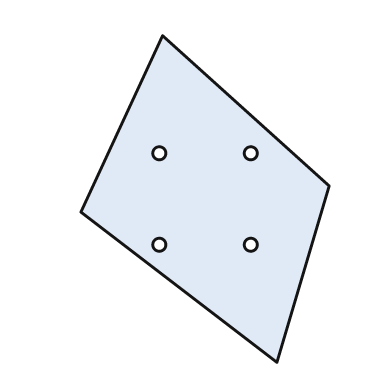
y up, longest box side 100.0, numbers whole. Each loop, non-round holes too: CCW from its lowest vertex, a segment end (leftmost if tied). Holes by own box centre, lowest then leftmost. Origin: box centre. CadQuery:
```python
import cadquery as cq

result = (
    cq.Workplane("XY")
    .moveTo(22.0, -50.0)
    .lineTo(38.0, 4.0)
    .lineTo(-13.0, 50.0)
    .lineTo(-38.0, -4.0)
    .close()
    .moveTo(-14.0, -14.0)
    .circle(2.0)
    .moveTo(14.0, -14.0)
    .circle(2.0)
    .moveTo(-14.0, 14.0)
    .circle(2.0)
    .moveTo(14.0, 14.0)
    .circle(2.0)
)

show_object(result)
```